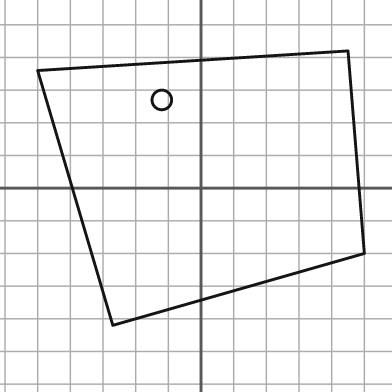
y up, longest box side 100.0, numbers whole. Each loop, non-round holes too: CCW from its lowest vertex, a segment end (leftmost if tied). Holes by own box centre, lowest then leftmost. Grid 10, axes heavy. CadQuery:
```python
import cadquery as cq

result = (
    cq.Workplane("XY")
    .moveTo(-27.0, -42.0)
    .lineTo(50.0, -20.0)
    .lineTo(45.0, 42.0)
    .lineTo(-50.0, 36.0)
    .close()
    .moveTo(-12.0, 27.0)
    .circle(3.0)
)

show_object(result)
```